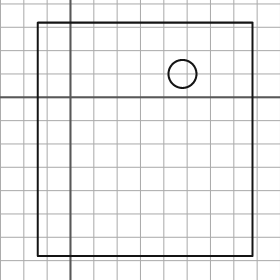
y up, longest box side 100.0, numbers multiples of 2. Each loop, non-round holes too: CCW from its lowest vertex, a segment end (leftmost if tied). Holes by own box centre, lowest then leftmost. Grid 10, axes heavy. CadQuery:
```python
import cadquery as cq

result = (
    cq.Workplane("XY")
    .moveTo(-14.0, -68.0)
    .lineTo(78.0, -68.0)
    .lineTo(78.0, 32.0)
    .lineTo(-14.0, 32.0)
    .close()
    .moveTo(48.0, 10.0)
    .circle(6.0)
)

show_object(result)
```